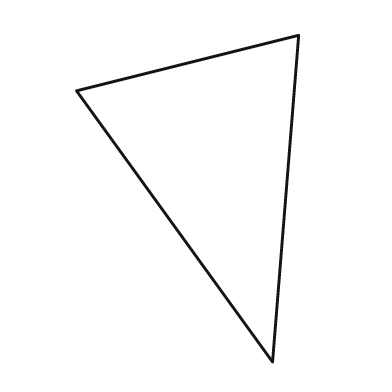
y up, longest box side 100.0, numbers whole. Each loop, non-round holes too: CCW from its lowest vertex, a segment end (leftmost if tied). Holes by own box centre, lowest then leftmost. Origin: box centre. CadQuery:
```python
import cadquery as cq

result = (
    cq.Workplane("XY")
    .moveTo(26.0, -50.0)
    .lineTo(34.0, 50.0)
    .lineTo(-34.0, 33.0)
    .close()
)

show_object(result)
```